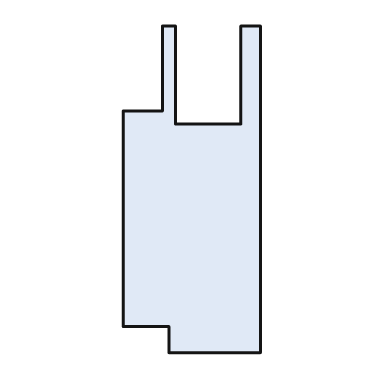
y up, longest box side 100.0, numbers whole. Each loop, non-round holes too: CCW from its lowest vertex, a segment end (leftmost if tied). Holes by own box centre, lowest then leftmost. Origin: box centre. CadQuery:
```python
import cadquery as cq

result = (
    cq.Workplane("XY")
    .moveTo(-7.0, -50.0)
    .lineTo(21.0, -50.0)
    .lineTo(21.0, 50.0)
    .lineTo(15.0, 50.0)
    .lineTo(15.0, 20.0)
    .lineTo(-5.0, 20.0)
    .lineTo(-5.0, 50.0)
    .lineTo(-9.0, 50.0)
    .lineTo(-9.0, 24.0)
    .lineTo(-21.0, 24.0)
    .lineTo(-21.0, -42.0)
    .lineTo(-7.0, -42.0)
    .close()
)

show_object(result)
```